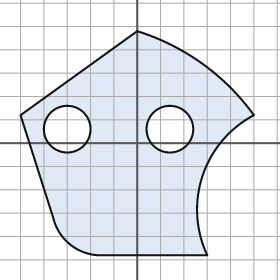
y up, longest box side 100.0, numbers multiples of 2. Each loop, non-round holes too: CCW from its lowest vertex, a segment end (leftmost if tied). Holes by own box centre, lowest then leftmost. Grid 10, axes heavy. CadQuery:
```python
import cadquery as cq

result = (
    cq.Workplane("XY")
    .moveTo(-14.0, -48.0)
    .lineTo(30.0, -48.0)
    .threePointArc((28.0, -14.0), (50.0, 12.0))
    .threePointArc((28.0, 34.0), (0.0, 48.0))
    .lineTo(-50.0, 12.0)
    .lineTo(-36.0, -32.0)
    .threePointArc((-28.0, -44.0), (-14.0, -48.0))
    .close()
    .moveTo(-30.0, 6.0)
    .circle(10.0)
    .moveTo(14.0, 6.0)
    .circle(10.0)
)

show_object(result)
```